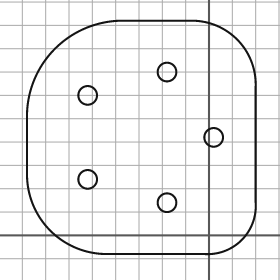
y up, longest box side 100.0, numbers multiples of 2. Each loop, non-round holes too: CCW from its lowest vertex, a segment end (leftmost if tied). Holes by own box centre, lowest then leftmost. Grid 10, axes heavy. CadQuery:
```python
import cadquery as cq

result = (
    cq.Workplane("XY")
    .moveTo(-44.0, -8.0)
    .lineTo(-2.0, -8.0)
    .threePointArc((14.0, -2.0), (20.0, 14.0))
    .lineTo(20.0, 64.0)
    .threePointArc((12.0, 84.0), (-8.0, 92.0))
    .lineTo(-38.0, 92.0)
    .threePointArc((-66.0, 80.0), (-78.0, 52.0))
    .lineTo(-78.0, 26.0)
    .threePointArc((-68.0, 2.0), (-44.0, -8.0))
    .close()
    .moveTo(-18.0, 14.0)
    .circle(4.0)
    .moveTo(-52.0, 24.0)
    .circle(4.0)
    .moveTo(2.0, 42.0)
    .circle(4.0)
    .moveTo(-52.0, 60.0)
    .circle(4.0)
    .moveTo(-18.0, 70.0)
    .circle(4.0)
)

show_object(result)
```